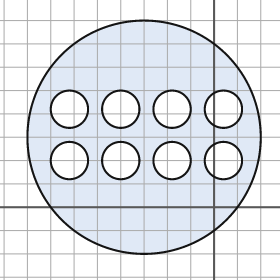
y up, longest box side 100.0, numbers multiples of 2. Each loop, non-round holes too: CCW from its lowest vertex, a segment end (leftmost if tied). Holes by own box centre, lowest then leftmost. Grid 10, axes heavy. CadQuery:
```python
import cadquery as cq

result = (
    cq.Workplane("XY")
    .moveTo(-30.0, 30.0)
    .circle(50.0)
    .moveTo(-62.0, 20.0)
    .circle(8.0)
    .moveTo(-40.0, 20.0)
    .circle(8.0)
    .moveTo(-18.0, 20.0)
    .circle(8.0)
    .moveTo(4.0, 20.0)
    .circle(8.0)
    .moveTo(-62.0, 42.0)
    .circle(8.0)
    .moveTo(-40.0, 42.0)
    .circle(8.0)
    .moveTo(-18.0, 42.0)
    .circle(8.0)
    .moveTo(4.0, 42.0)
    .circle(8.0)
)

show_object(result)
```